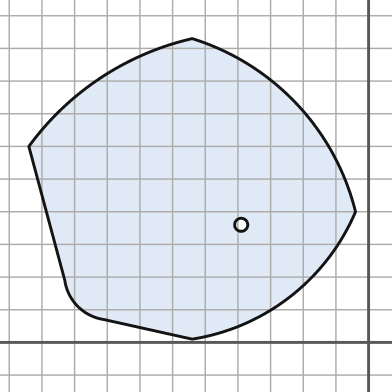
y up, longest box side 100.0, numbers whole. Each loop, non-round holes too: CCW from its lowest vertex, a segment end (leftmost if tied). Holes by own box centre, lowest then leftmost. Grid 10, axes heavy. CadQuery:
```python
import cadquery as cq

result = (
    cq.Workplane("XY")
    .moveTo(-54.0, 1.0)
    .threePointArc((-24.0, 14.0), (-4.0, 40.0))
    .threePointArc((-22.0, 73.0), (-54.0, 93.0))
    .threePointArc((-82.0, 81.0), (-104.0, 60.0))
    .lineTo(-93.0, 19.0)
    .threePointArc((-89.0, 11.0), (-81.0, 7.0))
    .close()
    .moveTo(-39.0, 36.0)
    .circle(2.0)
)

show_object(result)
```